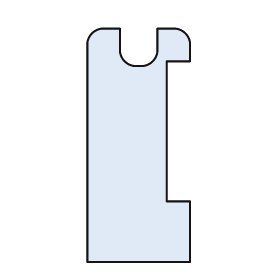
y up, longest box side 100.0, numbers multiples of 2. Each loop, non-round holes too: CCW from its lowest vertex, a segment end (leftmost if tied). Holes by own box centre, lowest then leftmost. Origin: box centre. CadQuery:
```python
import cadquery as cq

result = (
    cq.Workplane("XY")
    .moveTo(-22.0, -50.0)
    .lineTo(22.0, -50.0)
    .lineTo(22.0, -24.0)
    .lineTo(12.0, -24.0)
    .lineTo(12.0, 36.0)
    .lineTo(22.0, 36.0)
    .lineTo(22.0, 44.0)
    .threePointArc((20.0, 48.0), (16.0, 50.0))
    .lineTo(8.0, 50.0)
    .lineTo(8.0, 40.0)
    .threePointArc((6.0, 36.0), (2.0, 34.0))
    .lineTo(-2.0, 34.0)
    .threePointArc((-6.0, 36.0), (-8.0, 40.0))
    .lineTo(-8.0, 50.0)
    .lineTo(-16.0, 50.0)
    .threePointArc((-20.0, 48.0), (-22.0, 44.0))
    .close()
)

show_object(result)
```